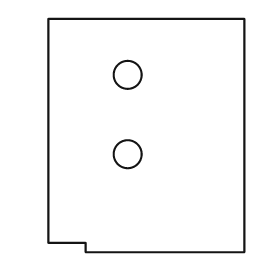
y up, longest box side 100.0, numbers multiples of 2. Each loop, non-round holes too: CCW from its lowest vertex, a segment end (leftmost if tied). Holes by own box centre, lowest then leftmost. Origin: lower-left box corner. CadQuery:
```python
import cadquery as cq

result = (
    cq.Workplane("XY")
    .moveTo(16.0, 0.0)
    .lineTo(84.0, 0.0)
    .lineTo(84.0, 100.0)
    .lineTo(0.0, 100.0)
    .lineTo(0.0, 4.0)
    .lineTo(16.0, 4.0)
    .close()
    .moveTo(34.0, 42.0)
    .circle(6.0)
    .moveTo(34.0, 76.0)
    .circle(6.0)
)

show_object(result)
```